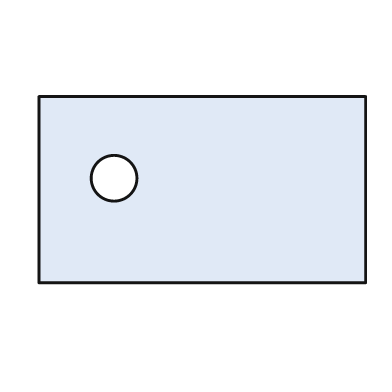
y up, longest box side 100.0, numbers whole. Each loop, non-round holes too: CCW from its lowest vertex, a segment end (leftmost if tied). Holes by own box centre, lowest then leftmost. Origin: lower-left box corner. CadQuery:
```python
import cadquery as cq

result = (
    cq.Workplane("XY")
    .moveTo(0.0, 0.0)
    .lineTo(100.0, 0.0)
    .lineTo(100.0, 57.0)
    .lineTo(0.0, 57.0)
    .close()
    .moveTo(23.0, 32.0)
    .circle(7.0)
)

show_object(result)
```